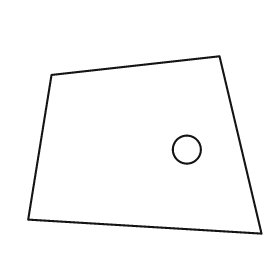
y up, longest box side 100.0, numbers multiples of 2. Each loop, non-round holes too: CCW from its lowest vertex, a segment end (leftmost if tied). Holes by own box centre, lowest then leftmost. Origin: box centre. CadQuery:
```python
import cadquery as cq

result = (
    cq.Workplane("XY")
    .moveTo(50.0, -38.0)
    .lineTo(32.0, 38.0)
    .lineTo(-40.0, 30.0)
    .lineTo(-50.0, -32.0)
    .close()
    .moveTo(18.0, -2.0)
    .circle(6.0)
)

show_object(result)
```